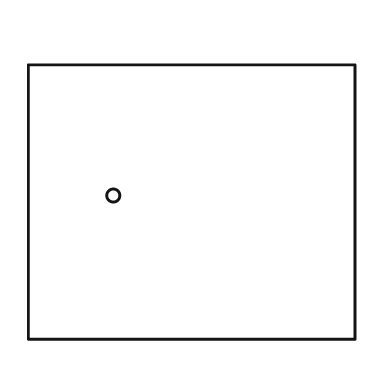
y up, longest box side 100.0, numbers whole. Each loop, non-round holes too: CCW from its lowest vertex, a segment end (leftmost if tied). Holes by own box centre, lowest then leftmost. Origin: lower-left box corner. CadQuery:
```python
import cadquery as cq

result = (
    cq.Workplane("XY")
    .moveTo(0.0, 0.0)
    .lineTo(100.0, 0.0)
    .lineTo(100.0, 84.0)
    .lineTo(0.0, 84.0)
    .close()
    .moveTo(26.0, 44.0)
    .circle(2.0)
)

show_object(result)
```